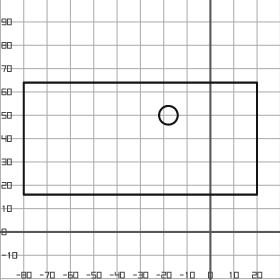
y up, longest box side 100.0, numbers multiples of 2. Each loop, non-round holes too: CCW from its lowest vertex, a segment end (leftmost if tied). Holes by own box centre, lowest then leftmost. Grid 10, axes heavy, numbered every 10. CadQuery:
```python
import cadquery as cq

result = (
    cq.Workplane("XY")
    .moveTo(-80.0, 16.0)
    .lineTo(20.0, 16.0)
    .lineTo(20.0, 64.0)
    .lineTo(-80.0, 64.0)
    .close()
    .moveTo(-18.0, 50.0)
    .circle(4.0)
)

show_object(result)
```